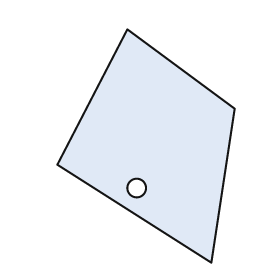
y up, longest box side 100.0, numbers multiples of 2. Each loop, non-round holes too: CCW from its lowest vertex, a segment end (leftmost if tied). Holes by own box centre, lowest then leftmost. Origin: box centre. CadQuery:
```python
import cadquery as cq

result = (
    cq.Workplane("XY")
    .moveTo(28.0, -50.0)
    .lineTo(38.0, 16.0)
    .lineTo(-8.0, 50.0)
    .lineTo(-38.0, -8.0)
    .close()
    .moveTo(-4.0, -18.0)
    .circle(4.0)
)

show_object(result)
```